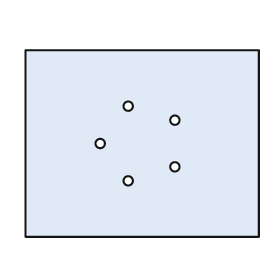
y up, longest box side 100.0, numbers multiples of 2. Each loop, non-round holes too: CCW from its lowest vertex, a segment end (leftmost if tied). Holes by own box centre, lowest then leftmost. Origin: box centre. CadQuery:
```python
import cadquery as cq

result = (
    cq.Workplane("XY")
    .moveTo(-50.0, -40.0)
    .lineTo(50.0, -40.0)
    .lineTo(50.0, 40.0)
    .lineTo(-50.0, 40.0)
    .close()
    .moveTo(-6.0, -16.0)
    .circle(2.0)
    .moveTo(14.0, -10.0)
    .circle(2.0)
    .moveTo(-18.0, 0.0)
    .circle(2.0)
    .moveTo(14.0, 10.0)
    .circle(2.0)
    .moveTo(-6.0, 16.0)
    .circle(2.0)
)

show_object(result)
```